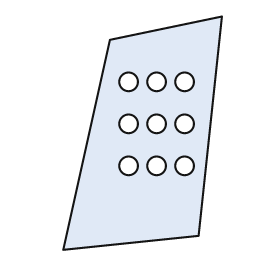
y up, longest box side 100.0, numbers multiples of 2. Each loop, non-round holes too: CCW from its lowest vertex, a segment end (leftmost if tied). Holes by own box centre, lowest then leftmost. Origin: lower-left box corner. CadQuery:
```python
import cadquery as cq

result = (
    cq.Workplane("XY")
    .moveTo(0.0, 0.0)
    .lineTo(58.0, 6.0)
    .lineTo(68.0, 100.0)
    .lineTo(20.0, 90.0)
    .close()
    .moveTo(28.0, 36.0)
    .circle(4.0)
    .moveTo(40.0, 36.0)
    .circle(4.0)
    .moveTo(52.0, 36.0)
    .circle(4.0)
    .moveTo(28.0, 54.0)
    .circle(4.0)
    .moveTo(40.0, 54.0)
    .circle(4.0)
    .moveTo(52.0, 54.0)
    .circle(4.0)
    .moveTo(28.0, 72.0)
    .circle(4.0)
    .moveTo(40.0, 72.0)
    .circle(4.0)
    .moveTo(52.0, 72.0)
    .circle(4.0)
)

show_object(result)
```